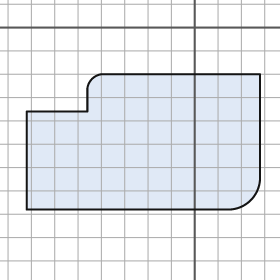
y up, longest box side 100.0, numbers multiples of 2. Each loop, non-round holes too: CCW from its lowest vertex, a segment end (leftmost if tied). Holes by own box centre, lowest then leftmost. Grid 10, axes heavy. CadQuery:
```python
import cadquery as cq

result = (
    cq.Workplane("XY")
    .moveTo(-72.0, -78.0)
    .lineTo(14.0, -78.0)
    .threePointArc((24.0, -74.0), (28.0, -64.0))
    .lineTo(28.0, -20.0)
    .lineTo(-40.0, -20.0)
    .threePointArc((-44.0, -22.0), (-46.0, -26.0))
    .lineTo(-46.0, -36.0)
    .lineTo(-72.0, -36.0)
    .close()
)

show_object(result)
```